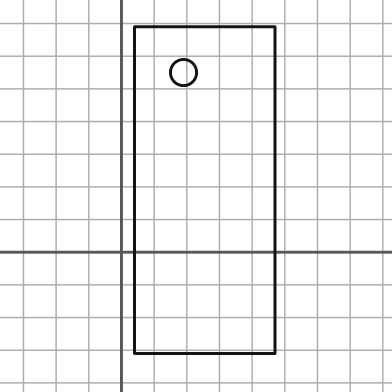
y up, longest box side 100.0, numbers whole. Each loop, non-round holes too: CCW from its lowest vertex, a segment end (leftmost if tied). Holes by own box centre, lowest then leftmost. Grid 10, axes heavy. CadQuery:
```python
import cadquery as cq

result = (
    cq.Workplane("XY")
    .moveTo(4.0, -31.0)
    .lineTo(47.0, -31.0)
    .lineTo(47.0, 69.0)
    .lineTo(4.0, 69.0)
    .close()
    .moveTo(19.0, 55.0)
    .circle(4.0)
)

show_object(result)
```